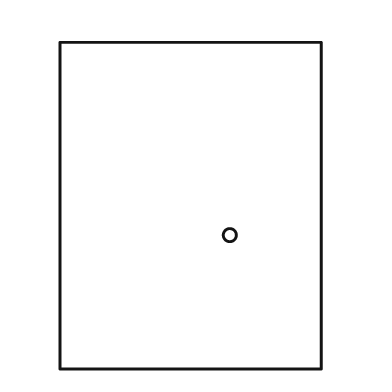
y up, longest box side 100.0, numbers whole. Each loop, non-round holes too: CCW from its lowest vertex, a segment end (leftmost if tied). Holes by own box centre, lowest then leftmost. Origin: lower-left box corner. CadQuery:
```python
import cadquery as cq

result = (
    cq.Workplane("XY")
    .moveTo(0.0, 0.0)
    .lineTo(80.0, 0.0)
    .lineTo(80.0, 100.0)
    .lineTo(0.0, 100.0)
    .close()
    .moveTo(52.0, 41.0)
    .circle(2.0)
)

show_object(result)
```